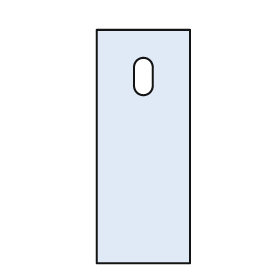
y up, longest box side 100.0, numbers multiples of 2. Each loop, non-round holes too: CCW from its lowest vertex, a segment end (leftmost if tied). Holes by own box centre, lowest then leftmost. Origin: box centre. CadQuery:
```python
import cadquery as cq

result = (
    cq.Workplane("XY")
    .moveTo(-20.0, -50.0)
    .lineTo(20.0, -50.0)
    .lineTo(20.0, 50.0)
    .lineTo(-20.0, 50.0)
    .close()
    .moveTo(-4.0, 26.0)
    .threePointArc((0.0, 22.0), (4.0, 26.0))
    .lineTo(4.0, 34.0)
    .threePointArc((0.0, 38.0), (-4.0, 34.0))
    .close()
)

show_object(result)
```